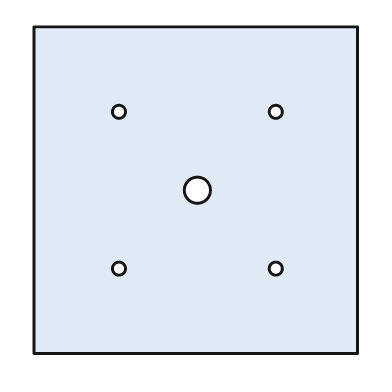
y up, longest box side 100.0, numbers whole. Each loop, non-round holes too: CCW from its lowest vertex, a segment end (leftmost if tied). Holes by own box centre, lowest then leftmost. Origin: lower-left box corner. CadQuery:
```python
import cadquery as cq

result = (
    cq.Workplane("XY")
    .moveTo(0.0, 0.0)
    .lineTo(99.0, 0.0)
    .lineTo(99.0, 100.0)
    .lineTo(0.0, 100.0)
    .close()
    .moveTo(26.0, 26.0)
    .circle(2.0)
    .moveTo(74.0, 26.0)
    .circle(2.0)
    .moveTo(50.0, 50.0)
    .circle(4.0)
    .moveTo(26.0, 74.0)
    .circle(2.0)
    .moveTo(74.0, 74.0)
    .circle(2.0)
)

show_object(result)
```